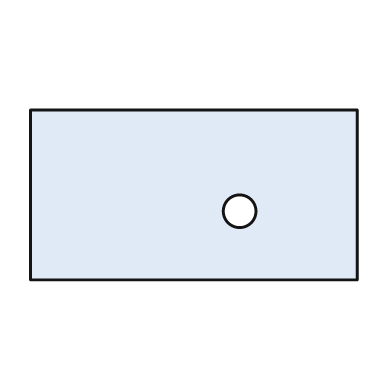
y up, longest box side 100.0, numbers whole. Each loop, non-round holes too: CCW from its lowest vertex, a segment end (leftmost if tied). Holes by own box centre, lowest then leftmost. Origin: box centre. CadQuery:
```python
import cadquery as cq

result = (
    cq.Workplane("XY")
    .moveTo(-50.0, -26.0)
    .lineTo(50.0, -26.0)
    .lineTo(50.0, 26.0)
    .lineTo(-50.0, 26.0)
    .close()
    .moveTo(14.0, -5.0)
    .circle(5.0)
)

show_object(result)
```